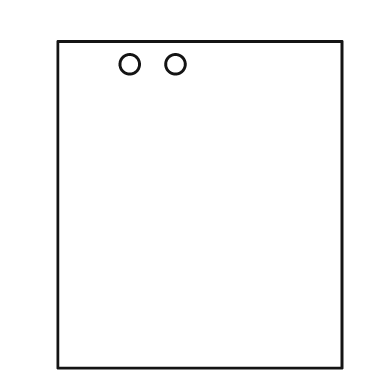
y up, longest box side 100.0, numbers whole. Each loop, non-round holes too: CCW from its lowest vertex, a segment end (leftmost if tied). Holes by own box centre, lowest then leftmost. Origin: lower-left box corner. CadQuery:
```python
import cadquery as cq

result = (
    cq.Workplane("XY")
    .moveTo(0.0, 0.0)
    .lineTo(87.0, 0.0)
    .lineTo(87.0, 100.0)
    .lineTo(0.0, 100.0)
    .close()
    .moveTo(22.0, 93.0)
    .circle(3.0)
    .moveTo(36.0, 93.0)
    .circle(3.0)
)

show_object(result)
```